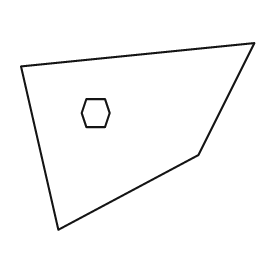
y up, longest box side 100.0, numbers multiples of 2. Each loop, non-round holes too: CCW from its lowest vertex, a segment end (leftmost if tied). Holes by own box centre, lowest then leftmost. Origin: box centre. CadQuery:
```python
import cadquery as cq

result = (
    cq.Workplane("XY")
    .moveTo(-34.0, -40.0)
    .lineTo(26.0, -8.0)
    .lineTo(50.0, 40.0)
    .lineTo(-50.0, 30.0)
    .close()
    .moveTo(-22.0, 4.0)
    .lineTo(-14.0, 4.0)
    .lineTo(-12.0, 10.0)
    .lineTo(-14.0, 16.0)
    .lineTo(-22.0, 16.0)
    .lineTo(-24.0, 10.0)
    .close()
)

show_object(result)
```